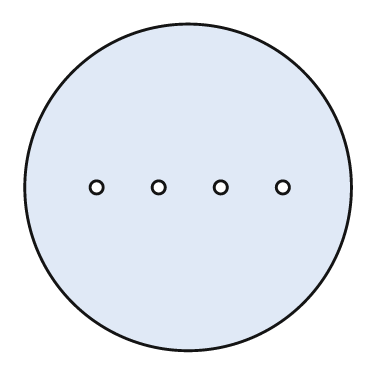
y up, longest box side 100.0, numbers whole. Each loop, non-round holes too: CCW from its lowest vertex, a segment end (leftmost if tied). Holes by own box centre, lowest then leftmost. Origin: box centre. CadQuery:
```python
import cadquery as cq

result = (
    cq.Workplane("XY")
    .moveTo(0.0, 0.0)
    .circle(50.0)
    .moveTo(-28.0, 0.0)
    .circle(2.0)
    .moveTo(-9.0, 0.0)
    .circle(2.0)
    .moveTo(10.0, 0.0)
    .circle(2.0)
    .moveTo(29.0, 0.0)
    .circle(2.0)
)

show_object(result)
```